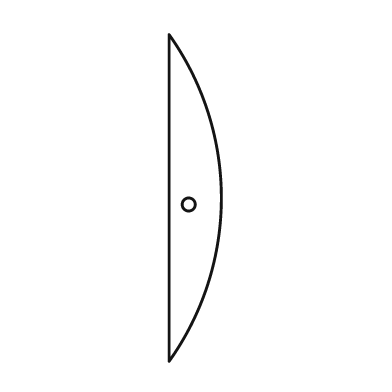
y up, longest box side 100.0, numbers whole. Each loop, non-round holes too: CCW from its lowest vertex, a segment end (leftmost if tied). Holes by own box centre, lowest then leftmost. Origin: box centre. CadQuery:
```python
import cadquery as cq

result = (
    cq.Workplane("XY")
    .moveTo(-8.0, -50.0)
    .threePointArc((8.0, 0.0), (-8.0, 50.0))
    .close()
    .moveTo(-2.0, -2.0)
    .circle(2.0)
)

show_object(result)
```